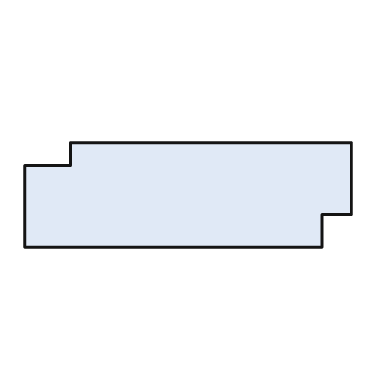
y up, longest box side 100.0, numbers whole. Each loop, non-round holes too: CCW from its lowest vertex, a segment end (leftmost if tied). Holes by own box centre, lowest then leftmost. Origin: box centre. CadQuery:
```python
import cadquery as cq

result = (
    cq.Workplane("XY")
    .moveTo(-50.0, -16.0)
    .lineTo(41.0, -16.0)
    .lineTo(41.0, -6.0)
    .lineTo(50.0, -6.0)
    .lineTo(50.0, 16.0)
    .lineTo(-36.0, 16.0)
    .lineTo(-36.0, 9.0)
    .lineTo(-50.0, 9.0)
    .close()
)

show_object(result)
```